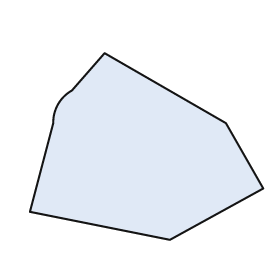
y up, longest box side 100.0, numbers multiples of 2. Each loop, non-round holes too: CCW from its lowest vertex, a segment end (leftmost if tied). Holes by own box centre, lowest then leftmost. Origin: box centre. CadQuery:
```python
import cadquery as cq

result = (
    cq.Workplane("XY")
    .moveTo(10.0, -40.0)
    .lineTo(50.0, -18.0)
    .lineTo(34.0, 10.0)
    .lineTo(-18.0, 40.0)
    .lineTo(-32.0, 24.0)
    .threePointArc((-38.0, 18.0), (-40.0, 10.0))
    .lineTo(-50.0, -28.0)
    .close()
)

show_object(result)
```